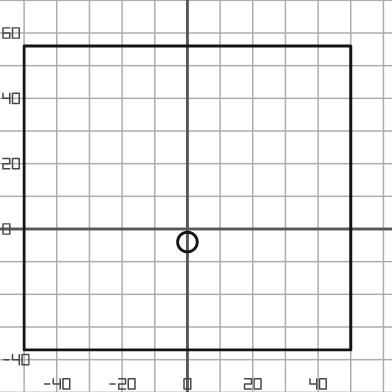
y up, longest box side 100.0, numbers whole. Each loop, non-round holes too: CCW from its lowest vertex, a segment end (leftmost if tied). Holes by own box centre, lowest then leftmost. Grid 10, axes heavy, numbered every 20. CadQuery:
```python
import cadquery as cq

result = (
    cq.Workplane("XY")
    .moveTo(-50.0, -37.0)
    .lineTo(50.0, -37.0)
    .lineTo(50.0, 56.0)
    .lineTo(-50.0, 56.0)
    .close()
    .moveTo(0.0, -4.0)
    .circle(3.0)
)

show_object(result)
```